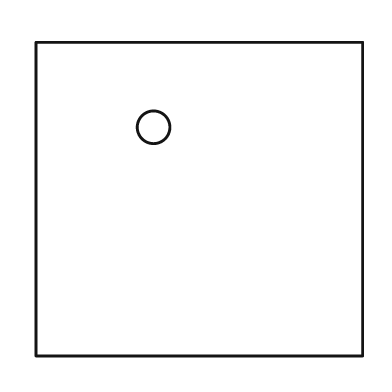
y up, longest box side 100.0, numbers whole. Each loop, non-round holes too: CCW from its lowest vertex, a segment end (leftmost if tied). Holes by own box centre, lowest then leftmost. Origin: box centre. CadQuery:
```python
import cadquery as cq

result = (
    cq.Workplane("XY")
    .moveTo(-50.0, -48.0)
    .lineTo(50.0, -48.0)
    .lineTo(50.0, 48.0)
    .lineTo(-50.0, 48.0)
    .close()
    .moveTo(-14.0, 22.0)
    .circle(5.0)
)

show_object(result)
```